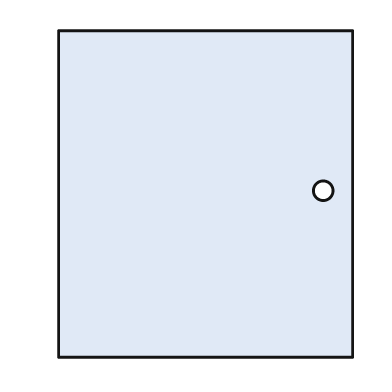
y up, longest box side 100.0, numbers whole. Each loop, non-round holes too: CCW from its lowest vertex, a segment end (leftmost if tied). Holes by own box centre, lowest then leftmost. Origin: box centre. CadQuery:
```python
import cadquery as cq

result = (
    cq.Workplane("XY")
    .moveTo(-45.0, -50.0)
    .lineTo(45.0, -50.0)
    .lineTo(45.0, 50.0)
    .lineTo(-45.0, 50.0)
    .close()
    .moveTo(36.0, 1.0)
    .circle(3.0)
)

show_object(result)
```